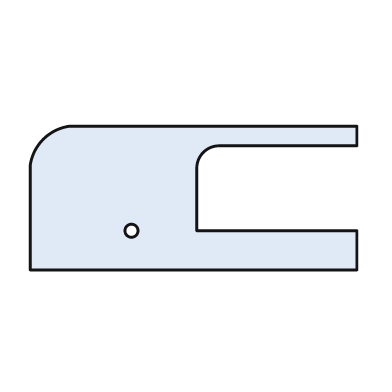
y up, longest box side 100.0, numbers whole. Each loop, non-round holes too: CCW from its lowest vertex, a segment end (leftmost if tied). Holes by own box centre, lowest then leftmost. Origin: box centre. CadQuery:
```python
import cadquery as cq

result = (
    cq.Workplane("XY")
    .moveTo(-50.0, -22.0)
    .lineTo(50.0, -22.0)
    .lineTo(50.0, -10.0)
    .lineTo(1.0, -10.0)
    .lineTo(1.0, 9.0)
    .threePointArc((3.0, 14.0), (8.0, 16.0))
    .lineTo(50.0, 16.0)
    .lineTo(50.0, 22.0)
    .lineTo(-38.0, 22.0)
    .threePointArc((-46.0, 18.0), (-50.0, 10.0))
    .close()
    .moveTo(-19.0, -10.0)
    .circle(2.0)
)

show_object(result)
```